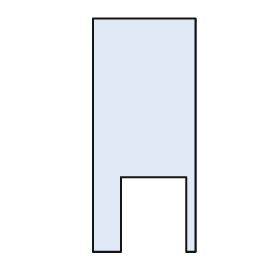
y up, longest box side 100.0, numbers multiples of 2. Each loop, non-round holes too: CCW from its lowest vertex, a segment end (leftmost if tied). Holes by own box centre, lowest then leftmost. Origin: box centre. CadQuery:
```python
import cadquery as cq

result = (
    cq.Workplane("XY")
    .moveTo(-22.0, -50.0)
    .lineTo(-10.0, -50.0)
    .lineTo(-10.0, -18.0)
    .lineTo(18.0, -18.0)
    .lineTo(18.0, -50.0)
    .lineTo(22.0, -50.0)
    .lineTo(22.0, 50.0)
    .lineTo(-22.0, 50.0)
    .close()
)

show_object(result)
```